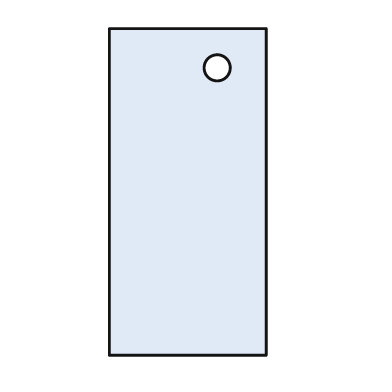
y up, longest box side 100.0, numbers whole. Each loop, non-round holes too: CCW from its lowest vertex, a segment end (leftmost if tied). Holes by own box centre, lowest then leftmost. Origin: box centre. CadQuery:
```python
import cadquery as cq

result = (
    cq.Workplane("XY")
    .moveTo(-24.0, -50.0)
    .lineTo(24.0, -50.0)
    .lineTo(24.0, 50.0)
    .lineTo(-24.0, 50.0)
    .close()
    .moveTo(9.0, 38.0)
    .circle(4.0)
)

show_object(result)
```